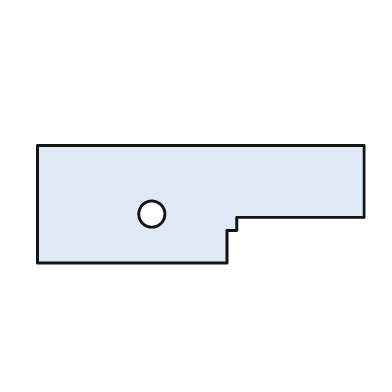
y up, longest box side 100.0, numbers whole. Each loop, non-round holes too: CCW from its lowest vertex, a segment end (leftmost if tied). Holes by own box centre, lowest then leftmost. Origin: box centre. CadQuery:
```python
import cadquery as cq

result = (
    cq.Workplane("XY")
    .moveTo(-50.0, -18.0)
    .lineTo(8.0, -18.0)
    .lineTo(8.0, -8.0)
    .lineTo(11.0, -8.0)
    .lineTo(11.0, -4.0)
    .lineTo(50.0, -4.0)
    .lineTo(50.0, 18.0)
    .lineTo(-50.0, 18.0)
    .close()
    .moveTo(-15.0, -3.0)
    .circle(4.0)
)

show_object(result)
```